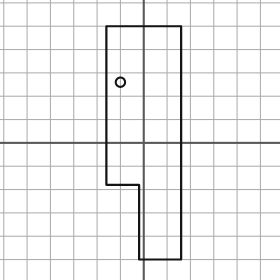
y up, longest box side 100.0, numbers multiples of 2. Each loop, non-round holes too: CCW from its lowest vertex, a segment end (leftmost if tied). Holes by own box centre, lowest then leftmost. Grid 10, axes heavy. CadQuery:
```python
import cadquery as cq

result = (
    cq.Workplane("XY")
    .moveTo(-2.0, -50.0)
    .lineTo(16.0, -50.0)
    .lineTo(16.0, 50.0)
    .lineTo(-16.0, 50.0)
    .lineTo(-16.0, -18.0)
    .lineTo(-2.0, -18.0)
    .close()
    .moveTo(-10.0, 26.0)
    .circle(2.0)
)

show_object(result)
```